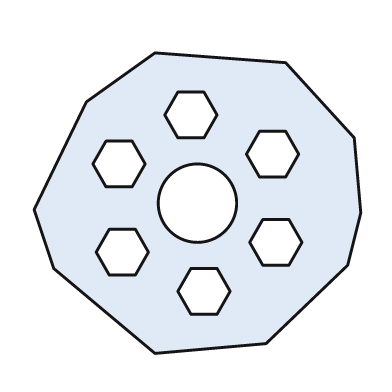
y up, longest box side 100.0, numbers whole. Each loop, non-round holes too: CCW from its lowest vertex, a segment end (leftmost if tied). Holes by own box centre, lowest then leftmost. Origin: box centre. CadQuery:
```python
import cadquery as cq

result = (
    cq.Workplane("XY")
    .moveTo(-13.0, -46.0)
    .lineTo(21.0, -43.0)
    .lineTo(46.0, -19.0)
    .lineTo(50.0, -3.0)
    .lineTo(48.0, 20.0)
    .lineTo(27.0, 43.0)
    .lineTo(-13.0, 46.0)
    .lineTo(-34.0, 31.0)
    .lineTo(-50.0, -2.0)
    .lineTo(-44.0, -20.0)
    .close()
    .moveTo(-2.0, -34.0)
    .lineTo(6.0, -34.0)
    .lineTo(10.0, -27.0)
    .lineTo(6.0, -20.0)
    .lineTo(-2.0, -20.0)
    .lineTo(-6.0, -27.0)
    .close()
    .moveTo(-27.0, -22.0)
    .lineTo(-19.0, -22.0)
    .lineTo(-15.0, -15.0)
    .lineTo(-19.0, -8.0)
    .lineTo(-27.0, -8.0)
    .lineTo(-31.0, -15.0)
    .close()
    .moveTo(20.0, -19.0)
    .lineTo(28.0, -19.0)
    .lineTo(32.0, -12.0)
    .lineTo(28.0, -5.0)
    .lineTo(20.0, -5.0)
    .lineTo(16.0, -12.0)
    .close()
    .moveTo(0.0, 0.0)
    .circle(12.0)
    .moveTo(-28.0, 5.0)
    .lineTo(-20.0, 5.0)
    .lineTo(-16.0, 12.0)
    .lineTo(-20.0, 19.0)
    .lineTo(-28.0, 19.0)
    .lineTo(-32.0, 12.0)
    .close()
    .moveTo(19.0, 8.0)
    .lineTo(27.0, 8.0)
    .lineTo(31.0, 15.0)
    .lineTo(27.0, 22.0)
    .lineTo(19.0, 22.0)
    .lineTo(15.0, 15.0)
    .close()
    .moveTo(-6.0, 20.0)
    .lineTo(2.0, 20.0)
    .lineTo(6.0, 27.0)
    .lineTo(2.0, 34.0)
    .lineTo(-6.0, 34.0)
    .lineTo(-10.0, 27.0)
    .close()
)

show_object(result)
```